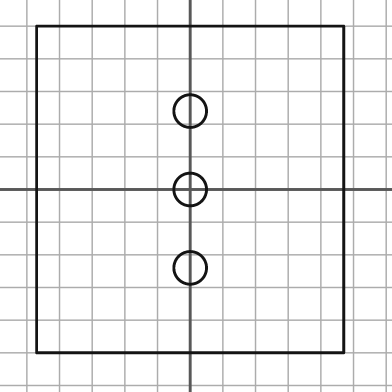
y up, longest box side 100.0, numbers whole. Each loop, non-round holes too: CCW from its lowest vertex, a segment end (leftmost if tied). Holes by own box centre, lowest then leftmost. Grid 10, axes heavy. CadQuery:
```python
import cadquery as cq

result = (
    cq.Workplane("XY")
    .moveTo(-47.0, -50.0)
    .lineTo(47.0, -50.0)
    .lineTo(47.0, 50.0)
    .lineTo(-47.0, 50.0)
    .close()
    .moveTo(0.0, -24.0)
    .circle(5.0)
    .moveTo(0.0, 0.0)
    .circle(5.0)
    .moveTo(0.0, 24.0)
    .circle(5.0)
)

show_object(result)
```